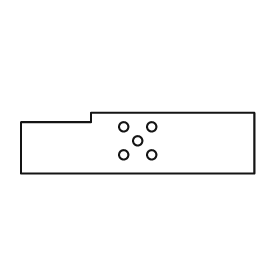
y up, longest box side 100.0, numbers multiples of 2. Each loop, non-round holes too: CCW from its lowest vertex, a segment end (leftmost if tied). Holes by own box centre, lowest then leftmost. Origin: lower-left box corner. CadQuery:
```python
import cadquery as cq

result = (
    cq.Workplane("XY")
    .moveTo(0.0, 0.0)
    .lineTo(100.0, 0.0)
    .lineTo(100.0, 26.0)
    .lineTo(30.0, 26.0)
    .lineTo(30.0, 22.0)
    .lineTo(0.0, 22.0)
    .close()
    .moveTo(44.0, 8.0)
    .circle(2.0)
    .moveTo(56.0, 8.0)
    .circle(2.0)
    .moveTo(50.0, 14.0)
    .circle(2.0)
    .moveTo(44.0, 20.0)
    .circle(2.0)
    .moveTo(56.0, 20.0)
    .circle(2.0)
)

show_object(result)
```